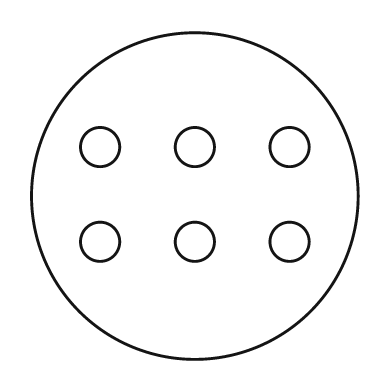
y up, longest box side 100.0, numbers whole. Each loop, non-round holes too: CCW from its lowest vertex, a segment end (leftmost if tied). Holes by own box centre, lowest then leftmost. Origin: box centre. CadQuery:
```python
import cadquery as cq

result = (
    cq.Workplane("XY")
    .moveTo(0.0, 0.0)
    .circle(50.0)
    .moveTo(-29.0, -14.0)
    .circle(6.0)
    .moveTo(0.0, -14.0)
    .circle(6.0)
    .moveTo(29.0, -14.0)
    .circle(6.0)
    .moveTo(-29.0, 15.0)
    .circle(6.0)
    .moveTo(0.0, 15.0)
    .circle(6.0)
    .moveTo(29.0, 15.0)
    .circle(6.0)
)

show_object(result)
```